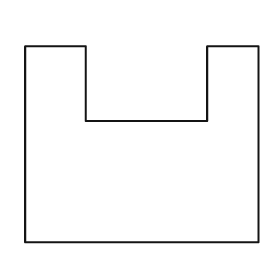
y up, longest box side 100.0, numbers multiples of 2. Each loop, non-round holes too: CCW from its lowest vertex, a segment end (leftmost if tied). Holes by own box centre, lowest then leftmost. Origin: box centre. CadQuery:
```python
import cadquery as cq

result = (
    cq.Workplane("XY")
    .moveTo(-50.0, -42.0)
    .lineTo(50.0, -42.0)
    .lineTo(50.0, 42.0)
    .lineTo(28.0, 42.0)
    .lineTo(28.0, 10.0)
    .lineTo(-24.0, 10.0)
    .lineTo(-24.0, 42.0)
    .lineTo(-50.0, 42.0)
    .close()
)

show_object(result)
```